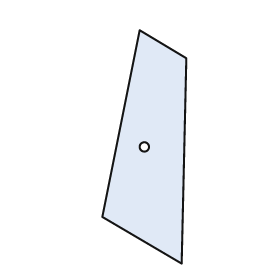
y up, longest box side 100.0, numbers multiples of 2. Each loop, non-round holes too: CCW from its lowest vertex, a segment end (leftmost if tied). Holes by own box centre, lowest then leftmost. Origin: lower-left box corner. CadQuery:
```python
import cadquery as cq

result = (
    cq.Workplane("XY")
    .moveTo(34.0, 0.0)
    .lineTo(36.0, 88.0)
    .lineTo(16.0, 100.0)
    .lineTo(0.0, 20.0)
    .close()
    .moveTo(18.0, 50.0)
    .circle(2.0)
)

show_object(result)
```